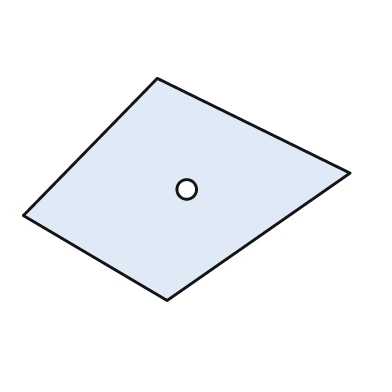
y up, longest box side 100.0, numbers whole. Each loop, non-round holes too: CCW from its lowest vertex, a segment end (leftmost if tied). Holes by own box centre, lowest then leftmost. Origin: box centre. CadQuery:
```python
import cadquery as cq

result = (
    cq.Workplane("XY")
    .moveTo(-6.0, -34.0)
    .lineTo(50.0, 5.0)
    .lineTo(-9.0, 34.0)
    .lineTo(-50.0, -8.0)
    .close()
    .moveTo(0.0, 0.0)
    .circle(3.0)
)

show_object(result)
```